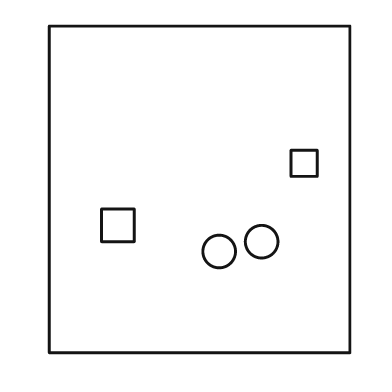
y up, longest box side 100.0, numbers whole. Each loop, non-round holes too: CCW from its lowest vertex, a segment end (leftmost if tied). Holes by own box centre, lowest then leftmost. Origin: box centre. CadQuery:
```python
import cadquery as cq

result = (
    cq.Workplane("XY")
    .moveTo(-46.0, -50.0)
    .lineTo(46.0, -50.0)
    .lineTo(46.0, 50.0)
    .lineTo(-46.0, 50.0)
    .close()
    .moveTo(6.0, -19.0)
    .circle(5.0)
    .moveTo(19.0, -16.0)
    .circle(5.0)
    .moveTo(-30.0, -16.0)
    .lineTo(-20.0, -16.0)
    .lineTo(-20.0, -6.0)
    .lineTo(-30.0, -6.0)
    .close()
    .moveTo(28.0, 4.0)
    .lineTo(36.0, 4.0)
    .lineTo(36.0, 12.0)
    .lineTo(28.0, 12.0)
    .close()
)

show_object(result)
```